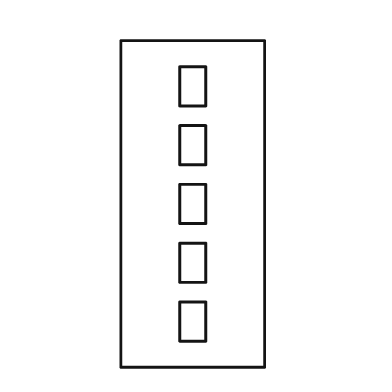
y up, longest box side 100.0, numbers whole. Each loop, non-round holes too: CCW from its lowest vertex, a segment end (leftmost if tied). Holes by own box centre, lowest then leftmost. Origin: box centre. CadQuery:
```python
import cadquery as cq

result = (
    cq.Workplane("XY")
    .moveTo(-22.0, -50.0)
    .lineTo(22.0, -50.0)
    .lineTo(22.0, 50.0)
    .lineTo(-22.0, 50.0)
    .close()
    .moveTo(-4.0, -42.0)
    .lineTo(4.0, -42.0)
    .lineTo(4.0, -30.0)
    .lineTo(-4.0, -30.0)
    .close()
    .moveTo(-4.0, -24.0)
    .lineTo(4.0, -24.0)
    .lineTo(4.0, -12.0)
    .lineTo(-4.0, -12.0)
    .close()
    .moveTo(-4.0, -6.0)
    .lineTo(4.0, -6.0)
    .lineTo(4.0, 6.0)
    .lineTo(-4.0, 6.0)
    .close()
    .moveTo(-4.0, 12.0)
    .lineTo(4.0, 12.0)
    .lineTo(4.0, 24.0)
    .lineTo(-4.0, 24.0)
    .close()
    .moveTo(-4.0, 30.0)
    .lineTo(4.0, 30.0)
    .lineTo(4.0, 42.0)
    .lineTo(-4.0, 42.0)
    .close()
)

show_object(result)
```